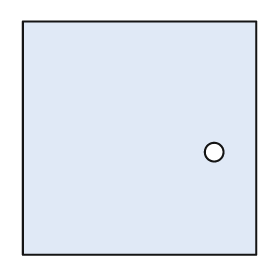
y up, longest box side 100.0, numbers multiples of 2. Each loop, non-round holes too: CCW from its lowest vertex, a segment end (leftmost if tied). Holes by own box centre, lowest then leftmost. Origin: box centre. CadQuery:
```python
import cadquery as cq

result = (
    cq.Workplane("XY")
    .moveTo(-50.0, -50.0)
    .lineTo(50.0, -50.0)
    .lineTo(50.0, 50.0)
    .lineTo(-50.0, 50.0)
    .close()
    .moveTo(32.0, -6.0)
    .circle(4.0)
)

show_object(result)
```